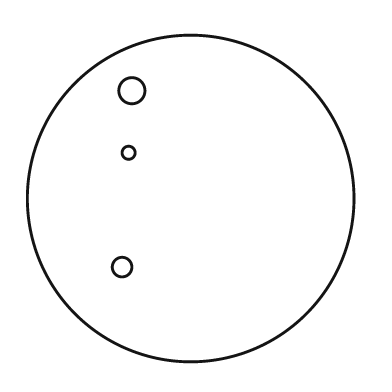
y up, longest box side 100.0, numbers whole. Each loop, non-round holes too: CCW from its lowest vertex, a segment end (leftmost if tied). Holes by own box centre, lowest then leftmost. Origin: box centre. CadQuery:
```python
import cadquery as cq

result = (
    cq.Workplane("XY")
    .moveTo(0.0, 0.0)
    .circle(50.0)
    .moveTo(-21.0, -21.0)
    .circle(3.0)
    .moveTo(-19.0, 14.0)
    .circle(2.0)
    .moveTo(-18.0, 33.0)
    .circle(4.0)
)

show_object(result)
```